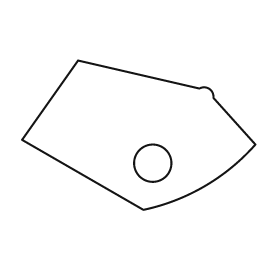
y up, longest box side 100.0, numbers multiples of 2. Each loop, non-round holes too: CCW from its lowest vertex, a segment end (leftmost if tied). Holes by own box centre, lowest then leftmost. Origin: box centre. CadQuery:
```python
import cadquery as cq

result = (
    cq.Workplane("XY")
    .moveTo(2.0, -32.0)
    .threePointArc((28.0, -22.0), (50.0, -4.0))
    .lineTo(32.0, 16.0)
    .threePointArc((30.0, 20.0), (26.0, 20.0))
    .lineTo(-26.0, 32.0)
    .lineTo(-50.0, -2.0)
    .close()
    .moveTo(6.0, -12.0)
    .circle(8.0)
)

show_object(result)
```